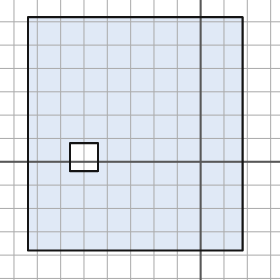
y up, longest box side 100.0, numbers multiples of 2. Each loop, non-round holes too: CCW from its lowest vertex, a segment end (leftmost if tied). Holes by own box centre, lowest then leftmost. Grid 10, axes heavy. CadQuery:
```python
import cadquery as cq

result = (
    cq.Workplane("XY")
    .moveTo(-74.0, -38.0)
    .lineTo(18.0, -38.0)
    .lineTo(18.0, 62.0)
    .lineTo(-74.0, 62.0)
    .close()
    .moveTo(-56.0, -4.0)
    .lineTo(-44.0, -4.0)
    .lineTo(-44.0, 8.0)
    .lineTo(-56.0, 8.0)
    .close()
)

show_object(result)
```